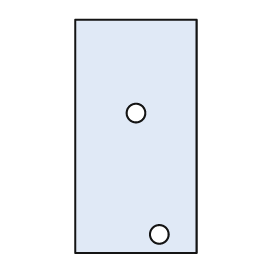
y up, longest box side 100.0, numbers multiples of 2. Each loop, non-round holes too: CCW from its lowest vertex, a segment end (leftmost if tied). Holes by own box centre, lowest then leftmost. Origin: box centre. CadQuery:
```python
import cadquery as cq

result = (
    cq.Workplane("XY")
    .moveTo(-26.0, -50.0)
    .lineTo(26.0, -50.0)
    .lineTo(26.0, 50.0)
    .lineTo(-26.0, 50.0)
    .close()
    .moveTo(10.0, -42.0)
    .circle(4.0)
    .moveTo(0.0, 10.0)
    .circle(4.0)
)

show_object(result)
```